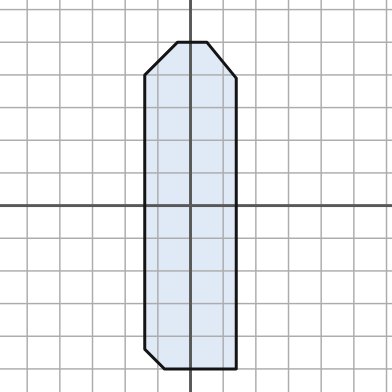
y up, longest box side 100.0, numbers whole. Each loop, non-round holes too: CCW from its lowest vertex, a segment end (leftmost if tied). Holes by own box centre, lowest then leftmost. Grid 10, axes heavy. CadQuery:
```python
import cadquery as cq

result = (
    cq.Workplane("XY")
    .moveTo(-8.0, -50.0)
    .lineTo(14.0, -50.0)
    .lineTo(14.0, 39.0)
    .lineTo(5.0, 50.0)
    .lineTo(-4.0, 50.0)
    .lineTo(-14.0, 40.0)
    .lineTo(-14.0, -44.0)
    .close()
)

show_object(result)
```